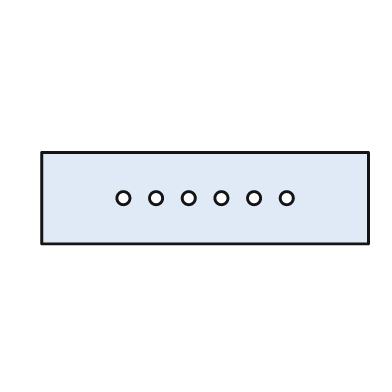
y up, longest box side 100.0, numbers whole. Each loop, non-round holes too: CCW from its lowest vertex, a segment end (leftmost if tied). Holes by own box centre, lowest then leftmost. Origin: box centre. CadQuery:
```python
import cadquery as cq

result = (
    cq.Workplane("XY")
    .moveTo(-50.0, -14.0)
    .lineTo(50.0, -14.0)
    .lineTo(50.0, 14.0)
    .lineTo(-50.0, 14.0)
    .close()
    .moveTo(-25.0, 0.0)
    .circle(2.0)
    .moveTo(-15.0, 0.0)
    .circle(2.0)
    .moveTo(-5.0, 0.0)
    .circle(2.0)
    .moveTo(5.0, 0.0)
    .circle(2.0)
    .moveTo(15.0, 0.0)
    .circle(2.0)
    .moveTo(25.0, 0.0)
    .circle(2.0)
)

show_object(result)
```